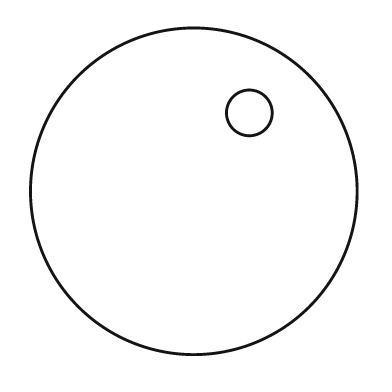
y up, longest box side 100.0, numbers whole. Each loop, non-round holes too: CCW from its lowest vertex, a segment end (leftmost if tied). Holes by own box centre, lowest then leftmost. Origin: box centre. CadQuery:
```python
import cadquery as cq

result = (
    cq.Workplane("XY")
    .moveTo(0.0, 0.0)
    .circle(50.0)
    .moveTo(17.0, 24.0)
    .circle(7.0)
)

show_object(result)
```